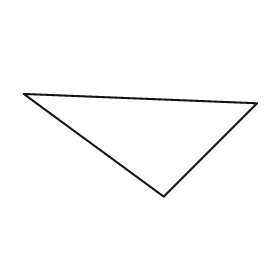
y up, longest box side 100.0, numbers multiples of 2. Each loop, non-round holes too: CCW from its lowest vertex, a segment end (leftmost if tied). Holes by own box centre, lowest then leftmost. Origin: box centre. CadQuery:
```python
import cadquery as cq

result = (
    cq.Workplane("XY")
    .moveTo(10.0, -22.0)
    .lineTo(50.0, 18.0)
    .lineTo(-50.0, 22.0)
    .close()
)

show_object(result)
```